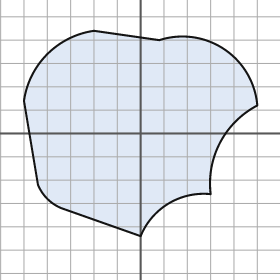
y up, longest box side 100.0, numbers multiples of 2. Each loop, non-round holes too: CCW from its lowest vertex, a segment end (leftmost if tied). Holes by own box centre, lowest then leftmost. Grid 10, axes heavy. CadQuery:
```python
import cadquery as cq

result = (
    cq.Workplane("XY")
    .moveTo(0.0, -44.0)
    .threePointArc((12.0, -30.0), (30.0, -26.0))
    .threePointArc((34.0, -4.0), (50.0, 12.0))
    .threePointArc((36.0, 36.0), (8.0, 40.0))
    .lineTo(-20.0, 44.0)
    .threePointArc((-40.0, 34.0), (-50.0, 14.0))
    .lineTo(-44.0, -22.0)
    .threePointArc((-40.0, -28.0), (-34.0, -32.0))
    .close()
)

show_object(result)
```